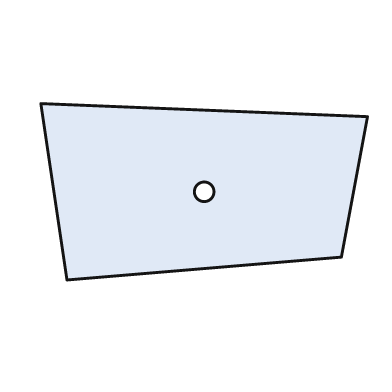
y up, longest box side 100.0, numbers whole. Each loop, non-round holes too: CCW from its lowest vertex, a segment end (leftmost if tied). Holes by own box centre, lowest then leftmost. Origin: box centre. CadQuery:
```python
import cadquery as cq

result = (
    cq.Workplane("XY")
    .moveTo(-42.0, -27.0)
    .lineTo(42.0, -20.0)
    .lineTo(50.0, 23.0)
    .lineTo(-50.0, 27.0)
    .close()
    .moveTo(0.0, 0.0)
    .circle(3.0)
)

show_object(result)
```